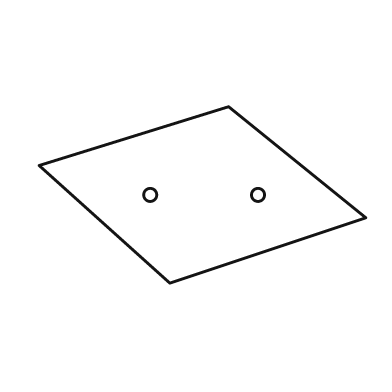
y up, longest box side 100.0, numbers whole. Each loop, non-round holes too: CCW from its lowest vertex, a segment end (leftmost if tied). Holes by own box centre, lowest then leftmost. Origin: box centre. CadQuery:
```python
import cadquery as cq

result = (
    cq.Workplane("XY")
    .moveTo(-10.0, -27.0)
    .lineTo(50.0, -7.0)
    .lineTo(8.0, 27.0)
    .lineTo(-50.0, 9.0)
    .close()
    .moveTo(-16.0, 0.0)
    .circle(2.0)
    .moveTo(17.0, 0.0)
    .circle(2.0)
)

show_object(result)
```